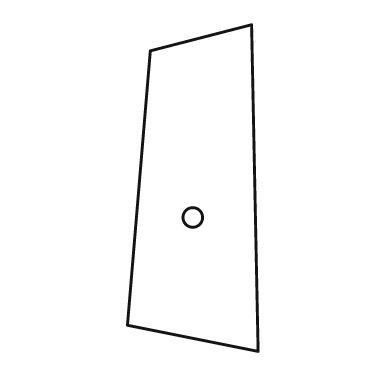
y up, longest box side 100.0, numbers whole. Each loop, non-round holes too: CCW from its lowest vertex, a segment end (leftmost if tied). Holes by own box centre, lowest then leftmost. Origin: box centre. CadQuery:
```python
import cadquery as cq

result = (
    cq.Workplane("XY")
    .moveTo(20.0, -50.0)
    .lineTo(18.0, 50.0)
    .lineTo(-13.0, 42.0)
    .lineTo(-20.0, -42.0)
    .close()
    .moveTo(0.0, -9.0)
    .circle(3.0)
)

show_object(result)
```